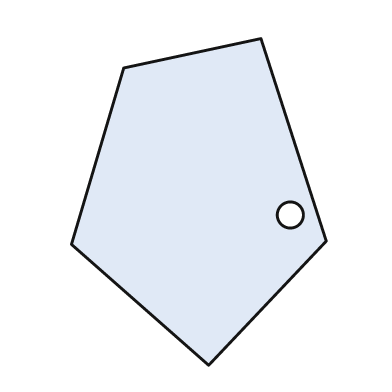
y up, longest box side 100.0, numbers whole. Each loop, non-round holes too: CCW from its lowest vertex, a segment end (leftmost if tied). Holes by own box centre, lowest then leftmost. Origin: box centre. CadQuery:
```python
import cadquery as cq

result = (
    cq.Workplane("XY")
    .moveTo(3.0, -50.0)
    .lineTo(39.0, -12.0)
    .lineTo(19.0, 50.0)
    .lineTo(-23.0, 41.0)
    .lineTo(-39.0, -13.0)
    .close()
    .moveTo(28.0, -4.0)
    .circle(4.0)
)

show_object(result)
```